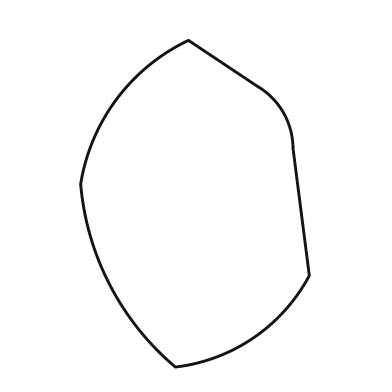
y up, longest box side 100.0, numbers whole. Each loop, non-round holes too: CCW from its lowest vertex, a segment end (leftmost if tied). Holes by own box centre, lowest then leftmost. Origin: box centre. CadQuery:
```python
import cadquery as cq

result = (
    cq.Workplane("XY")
    .moveTo(-6.0, -50.0)
    .threePointArc((18.0, -41.0), (35.0, -22.0))
    .lineTo(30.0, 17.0)
    .threePointArc((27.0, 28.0), (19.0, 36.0))
    .lineTo(-2.0, 50.0)
    .threePointArc((-24.0, 32.0), (-35.0, 6.0))
    .threePointArc((-26.0, -25.0), (-6.0, -50.0))
    .close()
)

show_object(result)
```